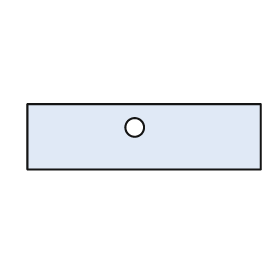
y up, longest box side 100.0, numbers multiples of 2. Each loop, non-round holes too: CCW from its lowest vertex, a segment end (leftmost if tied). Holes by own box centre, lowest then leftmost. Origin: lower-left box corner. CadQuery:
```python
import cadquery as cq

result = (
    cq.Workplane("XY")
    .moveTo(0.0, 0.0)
    .lineTo(100.0, 0.0)
    .lineTo(100.0, 28.0)
    .lineTo(0.0, 28.0)
    .close()
    .moveTo(46.0, 18.0)
    .circle(4.0)
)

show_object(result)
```